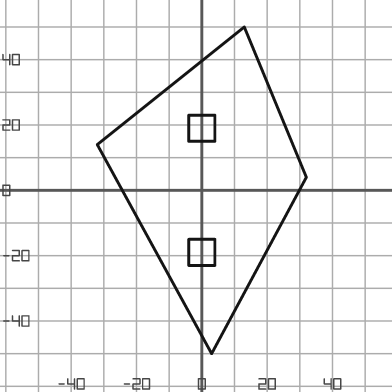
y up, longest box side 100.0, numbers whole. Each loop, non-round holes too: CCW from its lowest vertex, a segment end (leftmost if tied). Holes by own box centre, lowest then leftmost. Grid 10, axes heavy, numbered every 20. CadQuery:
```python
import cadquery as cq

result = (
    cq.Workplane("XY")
    .moveTo(3.0, -50.0)
    .lineTo(32.0, 4.0)
    .lineTo(13.0, 50.0)
    .lineTo(-32.0, 14.0)
    .close()
    .moveTo(-4.0, -23.0)
    .lineTo(4.0, -23.0)
    .lineTo(4.0, -15.0)
    .lineTo(-4.0, -15.0)
    .close()
    .moveTo(-4.0, 15.0)
    .lineTo(4.0, 15.0)
    .lineTo(4.0, 23.0)
    .lineTo(-4.0, 23.0)
    .close()
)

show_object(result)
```